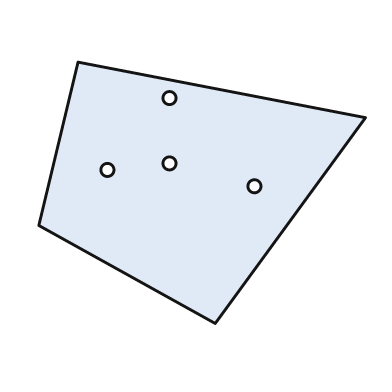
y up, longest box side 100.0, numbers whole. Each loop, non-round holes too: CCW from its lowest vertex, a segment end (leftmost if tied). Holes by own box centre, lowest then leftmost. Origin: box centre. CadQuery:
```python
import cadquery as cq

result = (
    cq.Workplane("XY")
    .moveTo(4.0, -40.0)
    .lineTo(50.0, 23.0)
    .lineTo(-38.0, 40.0)
    .lineTo(-50.0, -10.0)
    .close()
    .moveTo(16.0, 2.0)
    .circle(2.0)
    .moveTo(-29.0, 7.0)
    .circle(2.0)
    .moveTo(-10.0, 9.0)
    .circle(2.0)
    .moveTo(-10.0, 29.0)
    .circle(2.0)
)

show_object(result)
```